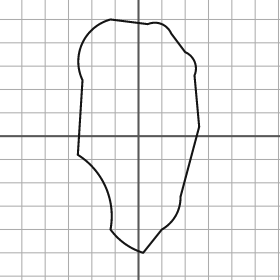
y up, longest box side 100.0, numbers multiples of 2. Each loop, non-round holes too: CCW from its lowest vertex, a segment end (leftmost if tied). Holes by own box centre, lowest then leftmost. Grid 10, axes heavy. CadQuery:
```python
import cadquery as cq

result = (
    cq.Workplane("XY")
    .moveTo(2.0, -50.0)
    .lineTo(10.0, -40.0)
    .threePointArc((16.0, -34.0), (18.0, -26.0))
    .lineTo(26.0, 4.0)
    .lineTo(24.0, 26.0)
    .threePointArc((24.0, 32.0), (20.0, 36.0))
    .lineTo(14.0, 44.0)
    .threePointArc((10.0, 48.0), (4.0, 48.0))
    .lineTo(-12.0, 50.0)
    .threePointArc((-24.0, 40.0), (-24.0, 24.0))
    .lineTo(-26.0, -8.0)
    .threePointArc((-14.0, -22.0), (-12.0, -40.0))
    .threePointArc((-6.0, -46.0), (2.0, -50.0))
    .close()
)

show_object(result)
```